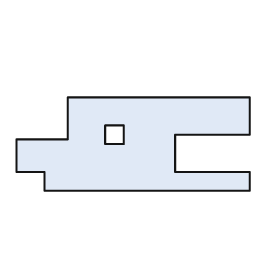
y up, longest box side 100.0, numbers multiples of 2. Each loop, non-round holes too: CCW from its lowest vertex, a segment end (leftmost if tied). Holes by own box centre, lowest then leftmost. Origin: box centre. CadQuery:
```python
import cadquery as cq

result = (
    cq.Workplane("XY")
    .moveTo(-38.0, -20.0)
    .lineTo(50.0, -20.0)
    .lineTo(50.0, -12.0)
    .lineTo(18.0, -12.0)
    .lineTo(18.0, 4.0)
    .lineTo(50.0, 4.0)
    .lineTo(50.0, 20.0)
    .lineTo(-28.0, 20.0)
    .lineTo(-28.0, 2.0)
    .lineTo(-50.0, 2.0)
    .lineTo(-50.0, -12.0)
    .lineTo(-38.0, -12.0)
    .close()
    .moveTo(-12.0, 0.0)
    .lineTo(-4.0, 0.0)
    .lineTo(-4.0, 8.0)
    .lineTo(-12.0, 8.0)
    .close()
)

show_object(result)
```